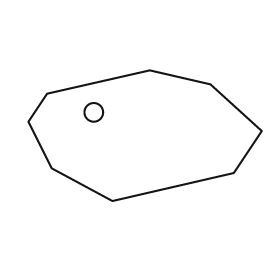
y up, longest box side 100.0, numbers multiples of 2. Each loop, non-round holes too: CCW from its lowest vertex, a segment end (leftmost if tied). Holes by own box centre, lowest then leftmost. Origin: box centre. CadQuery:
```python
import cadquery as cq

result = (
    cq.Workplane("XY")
    .moveTo(-14.0, -28.0)
    .lineTo(38.0, -16.0)
    .lineTo(50.0, 2.0)
    .lineTo(28.0, 22.0)
    .lineTo(2.0, 28.0)
    .lineTo(-42.0, 18.0)
    .lineTo(-50.0, 6.0)
    .lineTo(-40.0, -14.0)
    .close()
    .moveTo(-22.0, 10.0)
    .circle(4.0)
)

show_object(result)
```